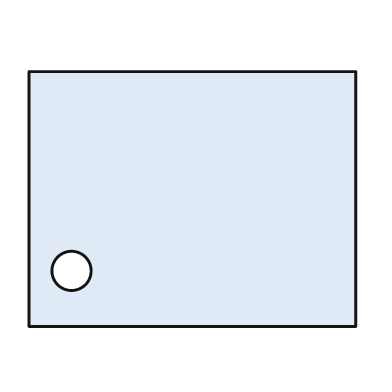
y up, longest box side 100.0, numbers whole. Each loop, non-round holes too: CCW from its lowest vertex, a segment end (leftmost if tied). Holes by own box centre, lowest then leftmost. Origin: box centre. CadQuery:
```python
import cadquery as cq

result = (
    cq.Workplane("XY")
    .moveTo(-50.0, -39.0)
    .lineTo(50.0, -39.0)
    .lineTo(50.0, 39.0)
    .lineTo(-50.0, 39.0)
    .close()
    .moveTo(-37.0, -22.0)
    .circle(6.0)
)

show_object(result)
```